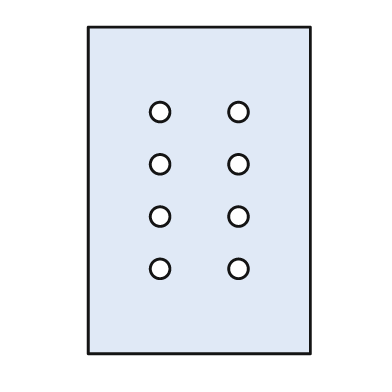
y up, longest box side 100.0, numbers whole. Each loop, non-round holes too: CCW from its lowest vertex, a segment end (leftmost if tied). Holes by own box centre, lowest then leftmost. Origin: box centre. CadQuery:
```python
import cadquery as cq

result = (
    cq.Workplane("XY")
    .moveTo(-34.0, -50.0)
    .lineTo(34.0, -50.0)
    .lineTo(34.0, 50.0)
    .lineTo(-34.0, 50.0)
    .close()
    .moveTo(-12.0, -24.0)
    .circle(3.0)
    .moveTo(12.0, -24.0)
    .circle(3.0)
    .moveTo(-12.0, -8.0)
    .circle(3.0)
    .moveTo(12.0, -8.0)
    .circle(3.0)
    .moveTo(-12.0, 8.0)
    .circle(3.0)
    .moveTo(12.0, 8.0)
    .circle(3.0)
    .moveTo(-12.0, 24.0)
    .circle(3.0)
    .moveTo(12.0, 24.0)
    .circle(3.0)
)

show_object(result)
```